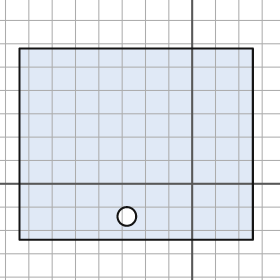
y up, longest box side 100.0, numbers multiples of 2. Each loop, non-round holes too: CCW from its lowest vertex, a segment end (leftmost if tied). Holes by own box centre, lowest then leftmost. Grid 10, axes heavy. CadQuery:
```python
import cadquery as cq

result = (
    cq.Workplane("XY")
    .moveTo(-74.0, -24.0)
    .lineTo(26.0, -24.0)
    .lineTo(26.0, 58.0)
    .lineTo(-74.0, 58.0)
    .close()
    .moveTo(-28.0, -14.0)
    .circle(4.0)
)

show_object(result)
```